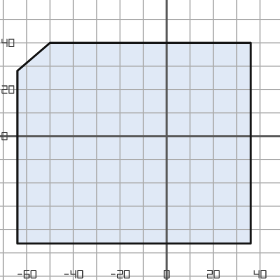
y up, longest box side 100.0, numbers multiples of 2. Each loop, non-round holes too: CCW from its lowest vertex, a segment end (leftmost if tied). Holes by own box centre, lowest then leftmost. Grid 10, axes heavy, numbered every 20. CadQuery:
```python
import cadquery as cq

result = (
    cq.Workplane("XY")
    .moveTo(-64.0, -46.0)
    .lineTo(36.0, -46.0)
    .lineTo(36.0, 40.0)
    .lineTo(-50.0, 40.0)
    .lineTo(-64.0, 28.0)
    .close()
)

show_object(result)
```